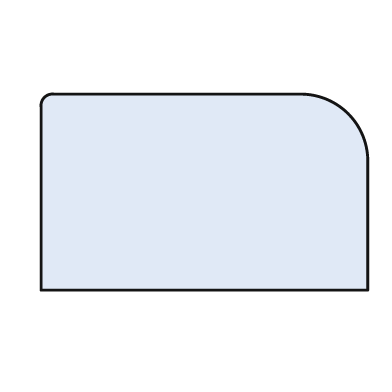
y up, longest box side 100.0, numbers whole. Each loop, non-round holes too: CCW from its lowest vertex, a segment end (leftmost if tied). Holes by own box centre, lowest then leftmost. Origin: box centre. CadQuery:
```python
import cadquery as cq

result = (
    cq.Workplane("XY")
    .moveTo(-50.0, -30.0)
    .lineTo(50.0, -30.0)
    .lineTo(50.0, 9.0)
    .threePointArc((44.0, 24.0), (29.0, 30.0))
    .lineTo(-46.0, 30.0)
    .threePointArc((-49.0, 29.0), (-50.0, 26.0))
    .close()
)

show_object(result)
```